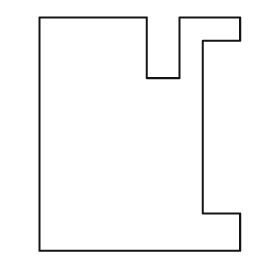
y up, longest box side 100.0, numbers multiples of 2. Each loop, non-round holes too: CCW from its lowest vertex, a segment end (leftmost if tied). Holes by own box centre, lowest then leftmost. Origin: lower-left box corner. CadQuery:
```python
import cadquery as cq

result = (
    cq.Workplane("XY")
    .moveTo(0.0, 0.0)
    .lineTo(86.0, 0.0)
    .lineTo(86.0, 16.0)
    .lineTo(70.0, 16.0)
    .lineTo(70.0, 90.0)
    .lineTo(86.0, 90.0)
    .lineTo(86.0, 100.0)
    .lineTo(60.0, 100.0)
    .lineTo(60.0, 74.0)
    .lineTo(46.0, 74.0)
    .lineTo(46.0, 100.0)
    .lineTo(0.0, 100.0)
    .close()
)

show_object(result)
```